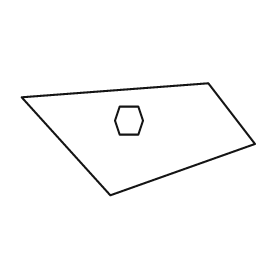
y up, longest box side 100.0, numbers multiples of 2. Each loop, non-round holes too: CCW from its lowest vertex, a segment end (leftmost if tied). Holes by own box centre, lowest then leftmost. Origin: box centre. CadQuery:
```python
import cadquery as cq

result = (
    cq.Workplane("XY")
    .moveTo(-12.0, -24.0)
    .lineTo(50.0, -2.0)
    .lineTo(30.0, 24.0)
    .lineTo(-50.0, 18.0)
    .close()
    .moveTo(-8.0, 2.0)
    .lineTo(0.0, 2.0)
    .lineTo(2.0, 8.0)
    .lineTo(0.0, 14.0)
    .lineTo(-8.0, 14.0)
    .lineTo(-10.0, 8.0)
    .close()
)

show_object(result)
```